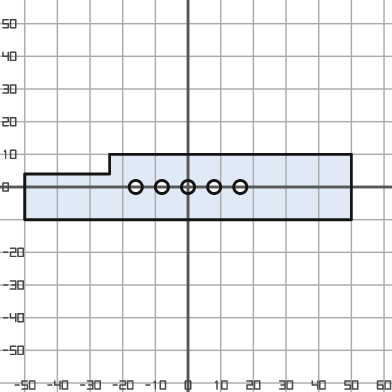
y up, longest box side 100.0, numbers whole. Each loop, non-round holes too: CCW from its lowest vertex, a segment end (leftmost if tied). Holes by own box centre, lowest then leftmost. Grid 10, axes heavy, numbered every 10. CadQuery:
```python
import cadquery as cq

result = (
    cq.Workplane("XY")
    .moveTo(-50.0, -10.0)
    .lineTo(50.0, -10.0)
    .lineTo(50.0, 10.0)
    .lineTo(-24.0, 10.0)
    .lineTo(-24.0, 4.0)
    .lineTo(-50.0, 4.0)
    .close()
    .moveTo(-16.0, 0.0)
    .circle(2.0)
    .moveTo(-8.0, 0.0)
    .circle(2.0)
    .moveTo(0.0, 0.0)
    .circle(2.0)
    .moveTo(8.0, 0.0)
    .circle(2.0)
    .moveTo(16.0, 0.0)
    .circle(2.0)
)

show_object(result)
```